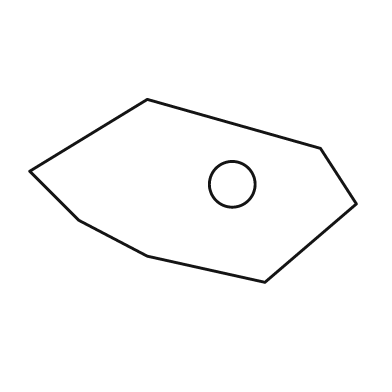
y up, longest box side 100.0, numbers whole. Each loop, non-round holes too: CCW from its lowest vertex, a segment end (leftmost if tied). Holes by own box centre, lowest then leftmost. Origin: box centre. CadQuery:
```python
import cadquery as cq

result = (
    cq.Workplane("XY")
    .moveTo(22.0, -28.0)
    .lineTo(50.0, -4.0)
    .lineTo(39.0, 13.0)
    .lineTo(-14.0, 28.0)
    .lineTo(-50.0, 6.0)
    .lineTo(-35.0, -9.0)
    .lineTo(-14.0, -20.0)
    .close()
    .moveTo(12.0, 2.0)
    .circle(7.0)
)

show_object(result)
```